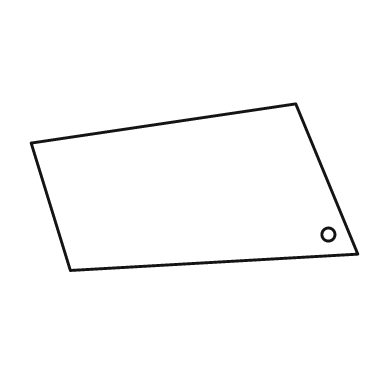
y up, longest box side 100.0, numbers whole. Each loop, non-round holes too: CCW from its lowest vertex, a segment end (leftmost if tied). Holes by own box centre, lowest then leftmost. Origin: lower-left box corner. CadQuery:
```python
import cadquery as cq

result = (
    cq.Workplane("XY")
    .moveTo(12.0, 0.0)
    .lineTo(100.0, 5.0)
    .lineTo(81.0, 51.0)
    .lineTo(0.0, 39.0)
    .close()
    .moveTo(91.0, 11.0)
    .circle(2.0)
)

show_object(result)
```